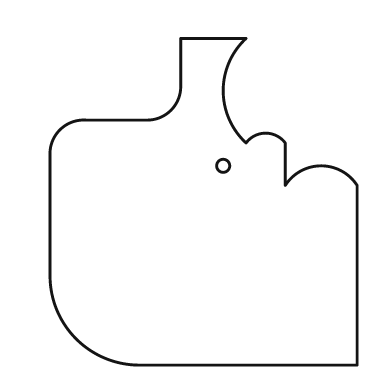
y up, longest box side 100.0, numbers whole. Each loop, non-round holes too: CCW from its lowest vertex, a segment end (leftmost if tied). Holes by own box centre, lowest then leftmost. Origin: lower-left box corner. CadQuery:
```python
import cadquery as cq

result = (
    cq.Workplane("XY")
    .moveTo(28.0, 0.0)
    .lineTo(94.0, 0.0)
    .lineTo(94.0, 55.0)
    .threePointArc((83.0, 61.0), (72.0, 55.0))
    .lineTo(72.0, 68.0)
    .threePointArc((66.0, 71.0), (60.0, 68.0))
    .threePointArc((53.0, 84.0), (60.0, 100.0))
    .lineTo(40.0, 100.0)
    .lineTo(40.0, 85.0)
    .threePointArc((37.0, 78.0), (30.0, 75.0))
    .lineTo(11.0, 75.0)
    .threePointArc((3.0, 72.0), (0.0, 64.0))
    .lineTo(0.0, 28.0)
    .threePointArc((8.0, 8.0), (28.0, 0.0))
    .close()
    .moveTo(53.0, 61.0)
    .circle(2.0)
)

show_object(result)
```